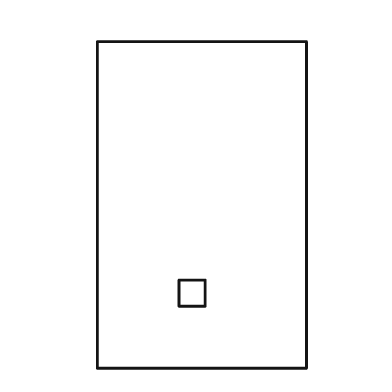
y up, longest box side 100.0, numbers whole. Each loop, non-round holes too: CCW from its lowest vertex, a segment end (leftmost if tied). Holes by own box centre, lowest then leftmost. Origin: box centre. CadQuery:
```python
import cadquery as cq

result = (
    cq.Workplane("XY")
    .moveTo(-32.0, -50.0)
    .lineTo(32.0, -50.0)
    .lineTo(32.0, 50.0)
    .lineTo(-32.0, 50.0)
    .close()
    .moveTo(-7.0, -31.0)
    .lineTo(1.0, -31.0)
    .lineTo(1.0, -23.0)
    .lineTo(-7.0, -23.0)
    .close()
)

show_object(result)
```